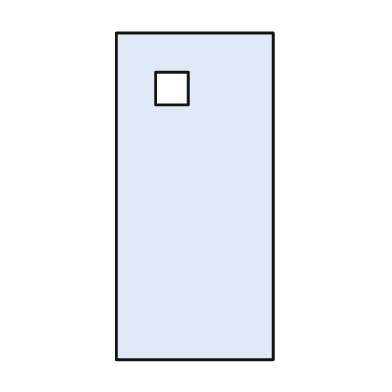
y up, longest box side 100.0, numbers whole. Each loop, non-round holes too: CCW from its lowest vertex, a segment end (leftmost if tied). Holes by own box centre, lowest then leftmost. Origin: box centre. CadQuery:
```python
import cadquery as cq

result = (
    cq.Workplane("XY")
    .moveTo(-24.0, -50.0)
    .lineTo(24.0, -50.0)
    .lineTo(24.0, 50.0)
    .lineTo(-24.0, 50.0)
    .close()
    .moveTo(-12.0, 28.0)
    .lineTo(-2.0, 28.0)
    .lineTo(-2.0, 38.0)
    .lineTo(-12.0, 38.0)
    .close()
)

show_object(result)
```